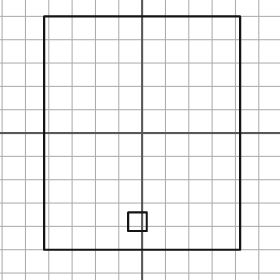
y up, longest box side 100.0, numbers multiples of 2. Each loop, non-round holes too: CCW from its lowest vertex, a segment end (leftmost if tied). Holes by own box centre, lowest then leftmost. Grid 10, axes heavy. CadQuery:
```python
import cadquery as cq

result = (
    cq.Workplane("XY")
    .moveTo(-42.0, -50.0)
    .lineTo(42.0, -50.0)
    .lineTo(42.0, 50.0)
    .lineTo(-42.0, 50.0)
    .close()
    .moveTo(-6.0, -42.0)
    .lineTo(2.0, -42.0)
    .lineTo(2.0, -34.0)
    .lineTo(-6.0, -34.0)
    .close()
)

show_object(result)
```